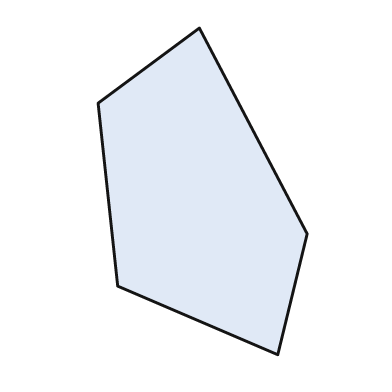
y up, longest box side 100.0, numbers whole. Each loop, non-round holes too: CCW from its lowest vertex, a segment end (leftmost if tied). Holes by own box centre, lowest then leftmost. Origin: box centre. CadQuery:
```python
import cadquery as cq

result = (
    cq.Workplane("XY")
    .moveTo(23.0, -50.0)
    .lineTo(32.0, -13.0)
    .lineTo(-1.0, 50.0)
    .lineTo(-32.0, 27.0)
    .lineTo(-26.0, -29.0)
    .close()
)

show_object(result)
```